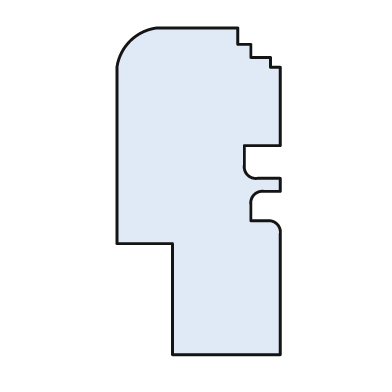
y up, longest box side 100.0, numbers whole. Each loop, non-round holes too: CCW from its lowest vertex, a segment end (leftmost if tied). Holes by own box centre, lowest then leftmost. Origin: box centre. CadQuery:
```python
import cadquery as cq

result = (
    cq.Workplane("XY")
    .moveTo(-8.0, -50.0)
    .lineTo(25.0, -50.0)
    .lineTo(25.0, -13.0)
    .threePointArc((24.0, -10.0), (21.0, -9.0))
    .lineTo(16.0, -9.0)
    .lineTo(16.0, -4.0)
    .threePointArc((17.0, -1.0), (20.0, 0.0))
    .lineTo(25.0, 0.0)
    .lineTo(25.0, 4.0)
    .lineTo(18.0, 4.0)
    .threePointArc((15.0, 5.0), (14.0, 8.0))
    .lineTo(14.0, 14.0)
    .lineTo(25.0, 14.0)
    .lineTo(25.0, 38.0)
    .lineTo(22.0, 38.0)
    .lineTo(22.0, 41.0)
    .lineTo(16.0, 41.0)
    .lineTo(16.0, 45.0)
    .lineTo(12.0, 45.0)
    .lineTo(12.0, 50.0)
    .lineTo(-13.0, 50.0)
    .threePointArc((-21.0, 46.0), (-25.0, 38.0))
    .lineTo(-25.0, -16.0)
    .lineTo(-8.0, -16.0)
    .close()
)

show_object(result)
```